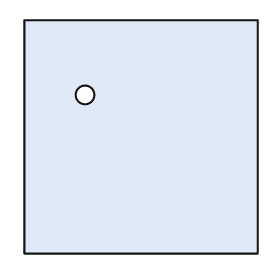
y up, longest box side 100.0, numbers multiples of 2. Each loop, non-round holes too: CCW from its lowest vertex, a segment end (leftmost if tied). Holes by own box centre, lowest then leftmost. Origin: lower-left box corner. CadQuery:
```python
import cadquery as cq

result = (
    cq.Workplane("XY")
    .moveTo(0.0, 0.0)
    .lineTo(100.0, 0.0)
    .lineTo(100.0, 100.0)
    .lineTo(0.0, 100.0)
    .close()
    .moveTo(26.0, 68.0)
    .circle(4.0)
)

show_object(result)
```